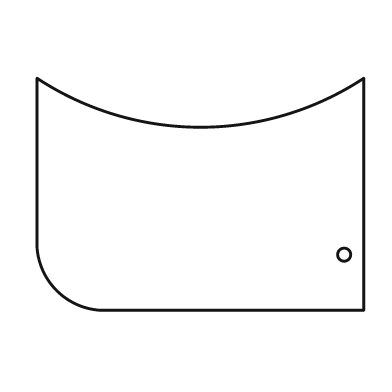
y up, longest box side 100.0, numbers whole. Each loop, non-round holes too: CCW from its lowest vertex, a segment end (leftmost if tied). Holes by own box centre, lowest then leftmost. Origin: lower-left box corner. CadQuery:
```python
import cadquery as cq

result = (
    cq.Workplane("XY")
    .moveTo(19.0, 0.0)
    .lineTo(100.0, 0.0)
    .lineTo(100.0, 71.0)
    .threePointArc((50.0, 56.0), (0.0, 71.0))
    .lineTo(0.0, 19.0)
    .threePointArc((6.0, 6.0), (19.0, 0.0))
    .close()
    .moveTo(94.0, 17.0)
    .circle(2.0)
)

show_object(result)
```